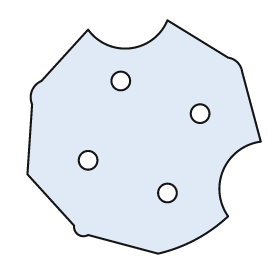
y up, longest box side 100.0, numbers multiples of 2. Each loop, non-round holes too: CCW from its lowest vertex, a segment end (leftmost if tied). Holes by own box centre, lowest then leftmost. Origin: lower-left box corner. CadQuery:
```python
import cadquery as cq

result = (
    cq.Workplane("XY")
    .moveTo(56.0, 0.0)
    .threePointArc((72.0, 6.0), (86.0, 16.0))
    .threePointArc((84.0, 36.0), (100.0, 48.0))
    .lineTo(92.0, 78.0)
    .threePointArc((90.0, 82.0), (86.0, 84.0))
    .lineTo(60.0, 100.0)
    .threePointArc((44.0, 88.0), (26.0, 96.0))
    .lineTo(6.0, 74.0)
    .threePointArc((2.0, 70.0), (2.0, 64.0))
    .lineTo(0.0, 34.0)
    .lineTo(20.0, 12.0)
    .threePointArc((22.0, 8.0), (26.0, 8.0))
    .close()
    .moveTo(60.0, 26.0)
    .circle(4.0)
    .moveTo(26.0, 40.0)
    .circle(4.0)
    .moveTo(74.0, 60.0)
    .circle(4.0)
    .moveTo(40.0, 74.0)
    .circle(4.0)
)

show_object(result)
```